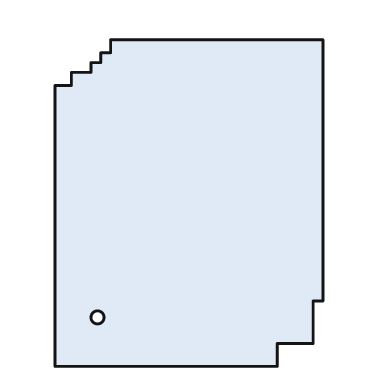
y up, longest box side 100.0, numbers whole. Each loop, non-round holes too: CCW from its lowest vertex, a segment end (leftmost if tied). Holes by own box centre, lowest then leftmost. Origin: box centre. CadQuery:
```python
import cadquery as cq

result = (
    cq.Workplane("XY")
    .moveTo(-41.0, -50.0)
    .lineTo(27.0, -50.0)
    .lineTo(27.0, -43.0)
    .lineTo(38.0, -43.0)
    .lineTo(38.0, -30.0)
    .lineTo(41.0, -30.0)
    .lineTo(41.0, 50.0)
    .lineTo(-24.0, 50.0)
    .lineTo(-24.0, 46.0)
    .lineTo(-27.0, 46.0)
    .lineTo(-27.0, 43.0)
    .lineTo(-30.0, 43.0)
    .lineTo(-30.0, 40.0)
    .lineTo(-36.0, 40.0)
    .lineTo(-36.0, 36.0)
    .lineTo(-41.0, 36.0)
    .close()
    .moveTo(-28.0, -35.0)
    .circle(2.0)
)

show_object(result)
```